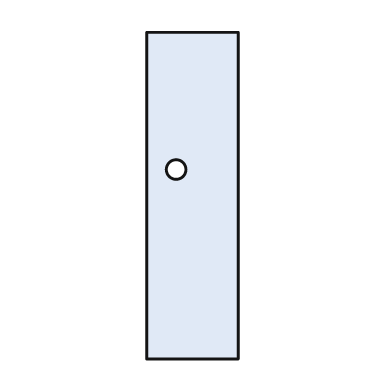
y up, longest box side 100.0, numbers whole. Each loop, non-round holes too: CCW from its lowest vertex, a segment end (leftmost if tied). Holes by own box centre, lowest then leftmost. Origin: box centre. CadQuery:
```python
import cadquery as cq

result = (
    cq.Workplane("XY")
    .moveTo(-14.0, -50.0)
    .lineTo(14.0, -50.0)
    .lineTo(14.0, 50.0)
    .lineTo(-14.0, 50.0)
    .close()
    .moveTo(-5.0, 8.0)
    .circle(3.0)
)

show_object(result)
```